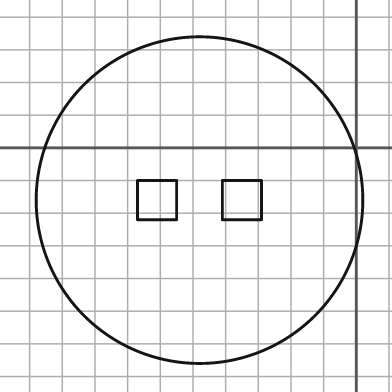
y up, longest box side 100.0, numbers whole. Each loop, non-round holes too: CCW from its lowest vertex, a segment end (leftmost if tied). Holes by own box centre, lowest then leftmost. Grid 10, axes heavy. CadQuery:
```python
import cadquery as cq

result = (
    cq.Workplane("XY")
    .moveTo(-48.0, -16.0)
    .circle(50.0)
    .moveTo(-67.0, -22.0)
    .lineTo(-55.0, -22.0)
    .lineTo(-55.0, -10.0)
    .lineTo(-67.0, -10.0)
    .close()
    .moveTo(-41.0, -22.0)
    .lineTo(-29.0, -22.0)
    .lineTo(-29.0, -10.0)
    .lineTo(-41.0, -10.0)
    .close()
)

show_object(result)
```